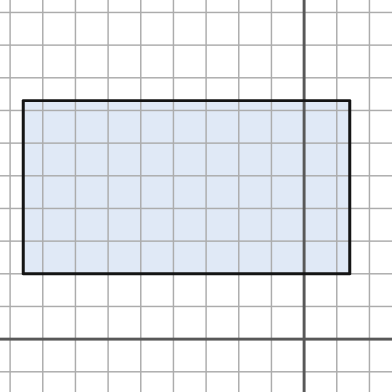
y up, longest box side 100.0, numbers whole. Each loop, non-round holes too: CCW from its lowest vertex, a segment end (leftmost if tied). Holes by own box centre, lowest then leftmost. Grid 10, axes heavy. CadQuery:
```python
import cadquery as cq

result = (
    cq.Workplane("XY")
    .moveTo(-86.0, 20.0)
    .lineTo(14.0, 20.0)
    .lineTo(14.0, 73.0)
    .lineTo(-86.0, 73.0)
    .close()
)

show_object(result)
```